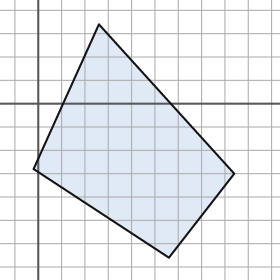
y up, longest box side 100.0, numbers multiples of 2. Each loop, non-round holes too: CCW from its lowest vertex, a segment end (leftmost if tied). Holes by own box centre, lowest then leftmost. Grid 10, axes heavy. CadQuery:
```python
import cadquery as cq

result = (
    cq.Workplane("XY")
    .moveTo(56.0, -66.0)
    .lineTo(84.0, -30.0)
    .lineTo(26.0, 34.0)
    .lineTo(-2.0, -28.0)
    .close()
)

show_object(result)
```